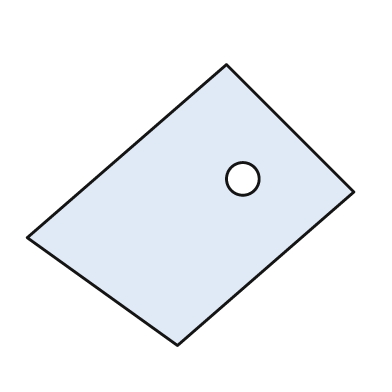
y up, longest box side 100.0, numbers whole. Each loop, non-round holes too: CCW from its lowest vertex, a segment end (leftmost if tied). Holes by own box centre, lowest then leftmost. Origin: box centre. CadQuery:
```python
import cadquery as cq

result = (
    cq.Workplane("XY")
    .moveTo(-4.0, -43.0)
    .lineTo(50.0, 4.0)
    .lineTo(11.0, 43.0)
    .lineTo(-50.0, -10.0)
    .close()
    .moveTo(16.0, 8.0)
    .circle(5.0)
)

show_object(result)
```